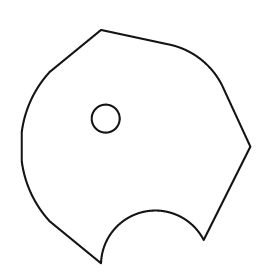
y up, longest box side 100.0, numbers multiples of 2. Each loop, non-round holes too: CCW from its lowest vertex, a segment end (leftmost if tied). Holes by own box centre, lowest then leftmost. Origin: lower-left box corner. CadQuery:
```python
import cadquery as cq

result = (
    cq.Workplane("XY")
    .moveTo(34.0, 0.0)
    .threePointArc((52.0, 22.0), (78.0, 10.0))
    .lineTo(98.0, 50.0)
    .lineTo(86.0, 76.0)
    .threePointArc((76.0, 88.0), (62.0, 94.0))
    .lineTo(34.0, 100.0)
    .lineTo(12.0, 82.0)
    .threePointArc((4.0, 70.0), (0.0, 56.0))
    .lineTo(0.0, 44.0)
    .threePointArc((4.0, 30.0), (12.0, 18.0))
    .close()
    .moveTo(36.0, 62.0)
    .circle(6.0)
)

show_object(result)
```